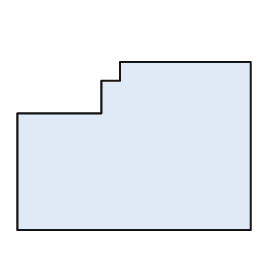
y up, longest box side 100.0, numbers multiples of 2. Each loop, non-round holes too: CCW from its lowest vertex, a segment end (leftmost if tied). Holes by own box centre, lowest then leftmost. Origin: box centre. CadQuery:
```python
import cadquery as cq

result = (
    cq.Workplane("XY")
    .moveTo(-50.0, -36.0)
    .lineTo(50.0, -36.0)
    .lineTo(50.0, 36.0)
    .lineTo(-6.0, 36.0)
    .lineTo(-6.0, 28.0)
    .lineTo(-14.0, 28.0)
    .lineTo(-14.0, 14.0)
    .lineTo(-50.0, 14.0)
    .close()
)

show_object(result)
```